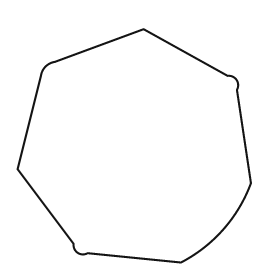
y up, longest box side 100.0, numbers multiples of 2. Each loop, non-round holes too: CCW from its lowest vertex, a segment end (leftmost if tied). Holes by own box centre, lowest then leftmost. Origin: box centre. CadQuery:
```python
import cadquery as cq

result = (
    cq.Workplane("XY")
    .moveTo(20.0, -50.0)
    .threePointArc((38.0, -36.0), (50.0, -16.0))
    .lineTo(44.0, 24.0)
    .threePointArc((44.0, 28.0), (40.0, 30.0))
    .lineTo(4.0, 50.0)
    .lineTo(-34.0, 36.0)
    .threePointArc((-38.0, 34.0), (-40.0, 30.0))
    .lineTo(-50.0, -10.0)
    .lineTo(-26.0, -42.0)
    .threePointArc((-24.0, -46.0), (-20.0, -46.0))
    .close()
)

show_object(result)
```